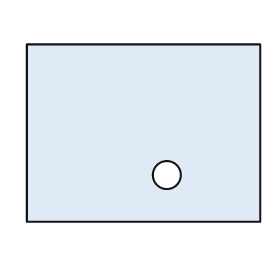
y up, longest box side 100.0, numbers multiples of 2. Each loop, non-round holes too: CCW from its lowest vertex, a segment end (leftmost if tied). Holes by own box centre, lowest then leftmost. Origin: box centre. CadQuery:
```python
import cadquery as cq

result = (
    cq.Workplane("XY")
    .moveTo(-50.0, -38.0)
    .lineTo(50.0, -38.0)
    .lineTo(50.0, 38.0)
    .lineTo(-50.0, 38.0)
    .close()
    .moveTo(10.0, -18.0)
    .circle(6.0)
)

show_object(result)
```